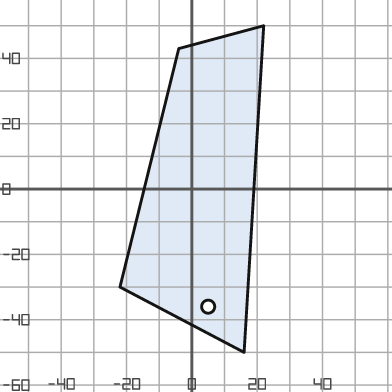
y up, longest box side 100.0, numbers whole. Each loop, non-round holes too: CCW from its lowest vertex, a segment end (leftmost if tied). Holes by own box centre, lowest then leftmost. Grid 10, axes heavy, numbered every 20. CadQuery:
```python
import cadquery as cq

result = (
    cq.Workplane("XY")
    .moveTo(16.0, -50.0)
    .lineTo(22.0, 50.0)
    .lineTo(-4.0, 43.0)
    .lineTo(-22.0, -30.0)
    .close()
    .moveTo(5.0, -36.0)
    .circle(2.0)
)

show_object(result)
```